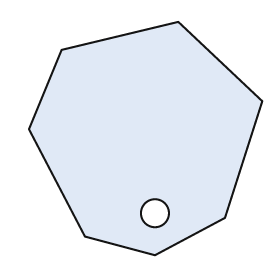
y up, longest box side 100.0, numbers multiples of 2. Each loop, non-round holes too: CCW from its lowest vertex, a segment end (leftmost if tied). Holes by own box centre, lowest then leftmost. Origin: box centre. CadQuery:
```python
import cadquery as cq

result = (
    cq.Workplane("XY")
    .moveTo(4.0, -50.0)
    .lineTo(34.0, -34.0)
    .lineTo(50.0, 16.0)
    .lineTo(14.0, 50.0)
    .lineTo(-36.0, 38.0)
    .lineTo(-50.0, 4.0)
    .lineTo(-26.0, -42.0)
    .close()
    .moveTo(4.0, -32.0)
    .circle(6.0)
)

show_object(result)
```